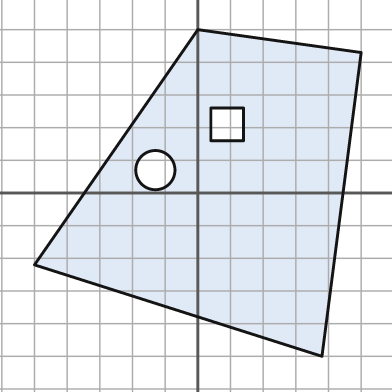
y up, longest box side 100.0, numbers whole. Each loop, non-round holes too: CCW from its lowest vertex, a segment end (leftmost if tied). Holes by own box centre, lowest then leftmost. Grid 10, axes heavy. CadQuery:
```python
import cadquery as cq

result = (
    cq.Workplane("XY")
    .moveTo(38.0, -50.0)
    .lineTo(50.0, 43.0)
    .lineTo(0.0, 50.0)
    .lineTo(-50.0, -22.0)
    .close()
    .moveTo(-13.0, 7.0)
    .circle(6.0)
    .moveTo(4.0, 16.0)
    .lineTo(14.0, 16.0)
    .lineTo(14.0, 26.0)
    .lineTo(4.0, 26.0)
    .close()
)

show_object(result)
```